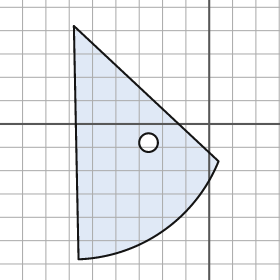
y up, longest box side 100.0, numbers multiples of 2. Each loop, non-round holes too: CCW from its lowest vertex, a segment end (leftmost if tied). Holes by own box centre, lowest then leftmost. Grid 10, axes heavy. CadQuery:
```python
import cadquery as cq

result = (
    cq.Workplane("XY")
    .moveTo(-56.0, -58.0)
    .threePointArc((-20.0, -46.0), (4.0, -16.0))
    .lineTo(-58.0, 42.0)
    .close()
    .moveTo(-26.0, -8.0)
    .circle(4.0)
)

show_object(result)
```